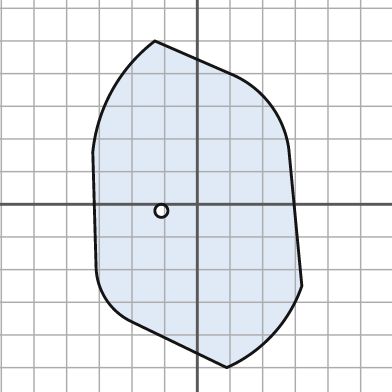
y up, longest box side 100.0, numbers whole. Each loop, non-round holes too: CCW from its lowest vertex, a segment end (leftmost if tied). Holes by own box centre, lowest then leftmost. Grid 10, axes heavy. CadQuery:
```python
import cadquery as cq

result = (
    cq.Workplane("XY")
    .moveTo(9.0, -50.0)
    .threePointArc((23.0, -40.0), (32.0, -25.0))
    .lineTo(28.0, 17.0)
    .threePointArc((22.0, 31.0), (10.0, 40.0))
    .lineTo(-13.0, 50.0)
    .threePointArc((-26.0, 35.0), (-32.0, 16.0))
    .lineTo(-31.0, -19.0)
    .threePointArc((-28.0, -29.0), (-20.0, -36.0))
    .close()
    .moveTo(-11.0, -2.0)
    .circle(2.0)
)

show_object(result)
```